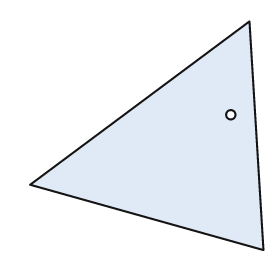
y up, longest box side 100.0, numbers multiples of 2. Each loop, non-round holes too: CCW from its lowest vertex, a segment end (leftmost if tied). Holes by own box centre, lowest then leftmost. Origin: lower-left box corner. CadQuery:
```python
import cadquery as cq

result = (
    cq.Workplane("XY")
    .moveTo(100.0, 0.0)
    .lineTo(94.0, 98.0)
    .lineTo(0.0, 28.0)
    .close()
    .moveTo(86.0, 58.0)
    .circle(2.0)
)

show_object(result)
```